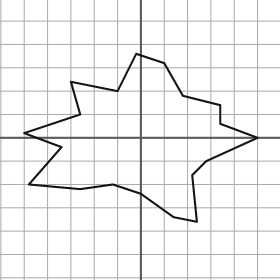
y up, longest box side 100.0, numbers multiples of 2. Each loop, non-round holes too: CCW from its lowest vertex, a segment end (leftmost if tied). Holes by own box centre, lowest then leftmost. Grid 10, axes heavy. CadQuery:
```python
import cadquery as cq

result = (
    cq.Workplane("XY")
    .moveTo(24.0, -36.0)
    .lineTo(22.0, -16.0)
    .lineTo(28.0, -10.0)
    .lineTo(50.0, 0.0)
    .lineTo(34.0, 6.0)
    .lineTo(34.0, 14.0)
    .lineTo(18.0, 18.0)
    .lineTo(10.0, 32.0)
    .lineTo(-2.0, 36.0)
    .lineTo(-10.0, 20.0)
    .lineTo(-30.0, 24.0)
    .lineTo(-26.0, 10.0)
    .lineTo(-50.0, 2.0)
    .lineTo(-34.0, -4.0)
    .lineTo(-48.0, -20.0)
    .lineTo(-26.0, -22.0)
    .lineTo(-12.0, -20.0)
    .lineTo(0.0, -24.0)
    .lineTo(14.0, -34.0)
    .close()
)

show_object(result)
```